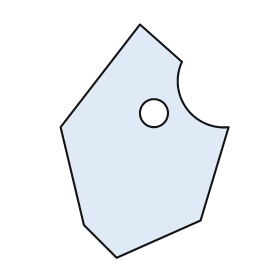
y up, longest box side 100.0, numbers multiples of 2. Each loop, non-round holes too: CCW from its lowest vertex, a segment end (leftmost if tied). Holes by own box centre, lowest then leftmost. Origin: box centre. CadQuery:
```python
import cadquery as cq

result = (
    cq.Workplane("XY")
    .moveTo(-12.0, -50.0)
    .lineTo(24.0, -34.0)
    .lineTo(36.0, 6.0)
    .threePointArc((18.0, 14.0), (16.0, 34.0))
    .lineTo(-2.0, 50.0)
    .lineTo(-36.0, 6.0)
    .lineTo(-26.0, -36.0)
    .close()
    .moveTo(4.0, 12.0)
    .circle(6.0)
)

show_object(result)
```